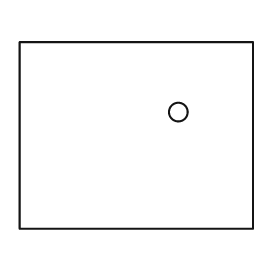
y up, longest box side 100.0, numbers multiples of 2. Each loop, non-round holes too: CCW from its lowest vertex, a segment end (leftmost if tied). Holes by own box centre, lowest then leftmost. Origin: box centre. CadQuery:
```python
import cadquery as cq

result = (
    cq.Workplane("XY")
    .moveTo(-50.0, -40.0)
    .lineTo(50.0, -40.0)
    .lineTo(50.0, 40.0)
    .lineTo(-50.0, 40.0)
    .close()
    .moveTo(18.0, 10.0)
    .circle(4.0)
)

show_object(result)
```